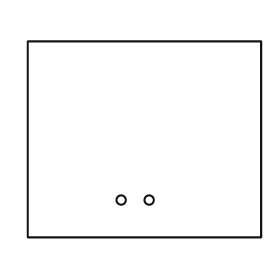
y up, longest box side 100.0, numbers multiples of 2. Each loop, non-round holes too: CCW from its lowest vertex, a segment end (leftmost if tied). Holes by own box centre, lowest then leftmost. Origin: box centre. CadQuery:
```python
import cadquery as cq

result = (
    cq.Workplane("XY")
    .moveTo(-50.0, -42.0)
    .lineTo(50.0, -42.0)
    .lineTo(50.0, 42.0)
    .lineTo(-50.0, 42.0)
    .close()
    .moveTo(-10.0, -26.0)
    .circle(2.0)
    .moveTo(2.0, -26.0)
    .circle(2.0)
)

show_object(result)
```